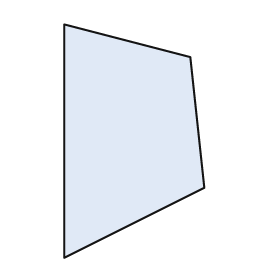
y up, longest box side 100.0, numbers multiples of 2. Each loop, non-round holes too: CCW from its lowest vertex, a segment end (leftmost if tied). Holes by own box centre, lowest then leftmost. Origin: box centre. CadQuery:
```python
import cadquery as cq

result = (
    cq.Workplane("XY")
    .moveTo(-30.0, -50.0)
    .lineTo(30.0, -20.0)
    .lineTo(24.0, 36.0)
    .lineTo(-30.0, 50.0)
    .close()
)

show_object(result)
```